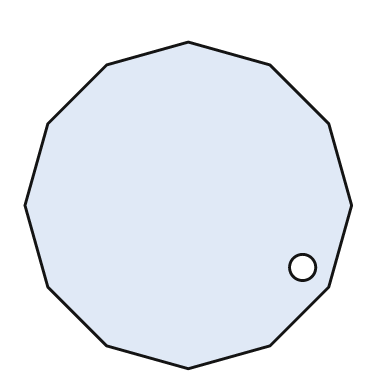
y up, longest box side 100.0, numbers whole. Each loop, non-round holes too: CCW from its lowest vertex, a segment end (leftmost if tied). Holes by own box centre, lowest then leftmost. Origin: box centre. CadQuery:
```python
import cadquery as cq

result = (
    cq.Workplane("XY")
    .moveTo(0.0, -50.0)
    .lineTo(25.0, -43.0)
    .lineTo(43.0, -25.0)
    .lineTo(50.0, 0.0)
    .lineTo(43.0, 25.0)
    .lineTo(25.0, 43.0)
    .lineTo(0.0, 50.0)
    .lineTo(-25.0, 43.0)
    .lineTo(-43.0, 25.0)
    .lineTo(-50.0, 0.0)
    .lineTo(-43.0, -25.0)
    .lineTo(-25.0, -43.0)
    .close()
    .moveTo(35.0, -19.0)
    .circle(4.0)
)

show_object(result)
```